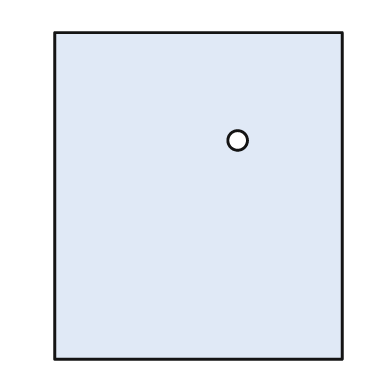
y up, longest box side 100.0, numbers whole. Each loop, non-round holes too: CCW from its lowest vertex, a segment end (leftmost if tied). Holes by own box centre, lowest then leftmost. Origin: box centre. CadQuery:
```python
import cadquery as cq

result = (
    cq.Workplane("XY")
    .moveTo(-44.0, -50.0)
    .lineTo(44.0, -50.0)
    .lineTo(44.0, 50.0)
    .lineTo(-44.0, 50.0)
    .close()
    .moveTo(12.0, 17.0)
    .circle(3.0)
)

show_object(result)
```